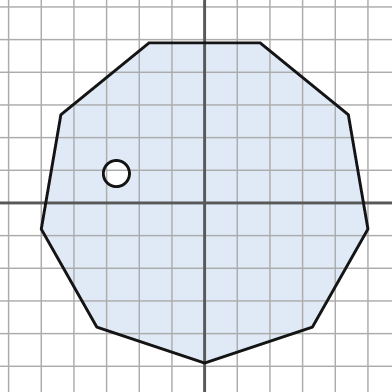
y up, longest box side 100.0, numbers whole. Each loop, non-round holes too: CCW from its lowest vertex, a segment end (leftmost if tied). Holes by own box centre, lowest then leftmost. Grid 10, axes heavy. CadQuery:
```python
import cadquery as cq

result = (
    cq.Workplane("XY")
    .moveTo(0.0, -49.0)
    .lineTo(33.0, -38.0)
    .lineTo(50.0, -8.0)
    .lineTo(44.0, 27.0)
    .lineTo(17.0, 49.0)
    .lineTo(-17.0, 49.0)
    .lineTo(-44.0, 27.0)
    .lineTo(-50.0, -8.0)
    .lineTo(-33.0, -38.0)
    .close()
    .moveTo(-27.0, 9.0)
    .circle(4.0)
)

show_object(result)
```